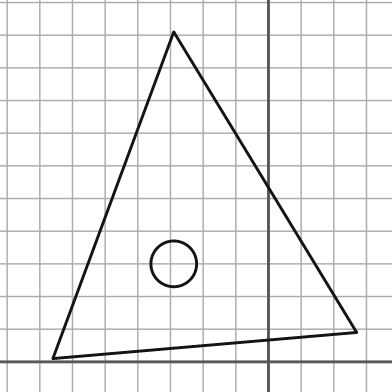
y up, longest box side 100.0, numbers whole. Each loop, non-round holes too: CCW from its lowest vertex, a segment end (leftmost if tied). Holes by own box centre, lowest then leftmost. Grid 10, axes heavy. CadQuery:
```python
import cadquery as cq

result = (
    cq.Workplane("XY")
    .moveTo(-66.0, 1.0)
    .lineTo(27.0, 9.0)
    .lineTo(-29.0, 101.0)
    .close()
    .moveTo(-29.0, 30.0)
    .circle(7.0)
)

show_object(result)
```